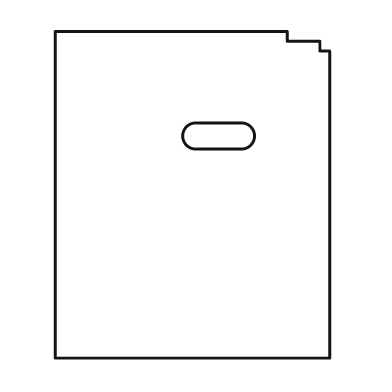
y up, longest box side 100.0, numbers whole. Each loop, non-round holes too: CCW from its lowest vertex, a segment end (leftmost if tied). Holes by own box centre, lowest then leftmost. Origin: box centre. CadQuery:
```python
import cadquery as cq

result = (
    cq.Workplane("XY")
    .moveTo(-42.0, -50.0)
    .lineTo(42.0, -50.0)
    .lineTo(42.0, 44.0)
    .lineTo(39.0, 44.0)
    .lineTo(39.0, 47.0)
    .lineTo(29.0, 47.0)
    .lineTo(29.0, 50.0)
    .lineTo(-42.0, 50.0)
    .close()
    .moveTo(1.0, 14.0)
    .lineTo(15.0, 14.0)
    .threePointArc((19.0, 18.0), (15.0, 22.0))
    .lineTo(1.0, 22.0)
    .threePointArc((-3.0, 18.0), (1.0, 14.0))
    .close()
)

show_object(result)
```